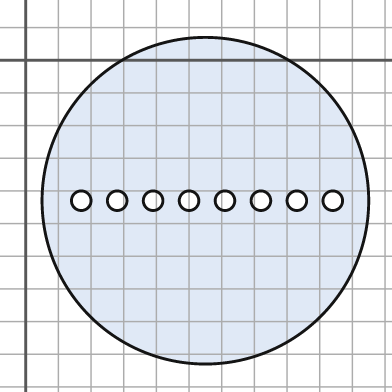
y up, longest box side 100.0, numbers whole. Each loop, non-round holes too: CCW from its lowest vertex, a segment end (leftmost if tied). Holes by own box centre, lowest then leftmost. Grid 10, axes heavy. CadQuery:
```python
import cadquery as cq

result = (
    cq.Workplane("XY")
    .moveTo(55.0, -43.0)
    .circle(50.0)
    .moveTo(17.0, -43.0)
    .circle(3.0)
    .moveTo(28.0, -43.0)
    .circle(3.0)
    .moveTo(39.0, -43.0)
    .circle(3.0)
    .moveTo(50.0, -43.0)
    .circle(3.0)
    .moveTo(61.0, -43.0)
    .circle(3.0)
    .moveTo(72.0, -43.0)
    .circle(3.0)
    .moveTo(83.0, -43.0)
    .circle(3.0)
    .moveTo(94.0, -43.0)
    .circle(3.0)
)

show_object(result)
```